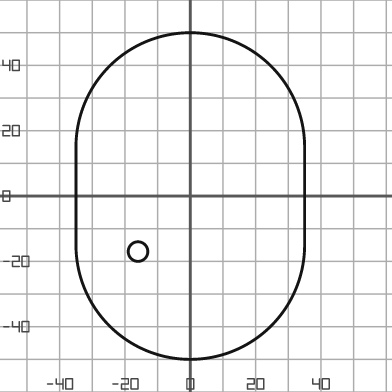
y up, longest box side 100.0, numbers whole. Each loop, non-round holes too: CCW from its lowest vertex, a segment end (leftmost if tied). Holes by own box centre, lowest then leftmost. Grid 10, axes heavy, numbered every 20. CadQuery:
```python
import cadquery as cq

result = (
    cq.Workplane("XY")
    .moveTo(-35.0, -15.0)
    .threePointArc((0.0, -50.0), (35.0, -15.0))
    .lineTo(35.0, 15.0)
    .threePointArc((0.0, 50.0), (-35.0, 15.0))
    .close()
    .moveTo(-16.0, -17.0)
    .circle(3.0)
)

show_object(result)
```